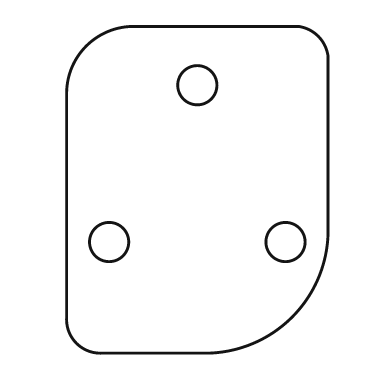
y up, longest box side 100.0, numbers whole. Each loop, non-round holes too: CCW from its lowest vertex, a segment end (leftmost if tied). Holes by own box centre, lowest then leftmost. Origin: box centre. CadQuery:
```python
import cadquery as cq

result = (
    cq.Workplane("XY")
    .moveTo(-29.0, -50.0)
    .lineTo(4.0, -50.0)
    .threePointArc((29.0, -39.0), (40.0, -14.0))
    .lineTo(40.0, 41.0)
    .threePointArc((37.0, 47.0), (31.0, 50.0))
    .lineTo(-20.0, 50.0)
    .threePointArc((-34.0, 44.0), (-40.0, 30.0))
    .lineTo(-40.0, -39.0)
    .threePointArc((-37.0, -47.0), (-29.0, -50.0))
    .close()
    .moveTo(-27.0, -16.0)
    .circle(6.0)
    .moveTo(27.0, -16.0)
    .circle(6.0)
    .moveTo(0.0, 32.0)
    .circle(6.0)
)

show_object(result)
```